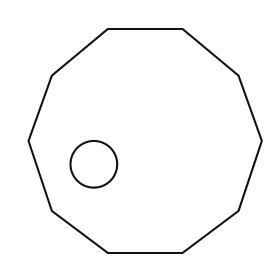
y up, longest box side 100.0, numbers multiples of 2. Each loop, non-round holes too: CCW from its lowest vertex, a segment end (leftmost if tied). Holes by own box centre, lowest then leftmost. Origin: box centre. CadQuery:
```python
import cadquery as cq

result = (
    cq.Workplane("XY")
    .moveTo(-16.0, -48.0)
    .lineTo(16.0, -48.0)
    .lineTo(40.0, -30.0)
    .lineTo(50.0, 0.0)
    .lineTo(40.0, 28.0)
    .lineTo(16.0, 48.0)
    .lineTo(-16.0, 48.0)
    .lineTo(-40.0, 28.0)
    .lineTo(-50.0, 0.0)
    .lineTo(-40.0, -30.0)
    .close()
    .moveTo(-22.0, -10.0)
    .circle(10.0)
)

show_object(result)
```